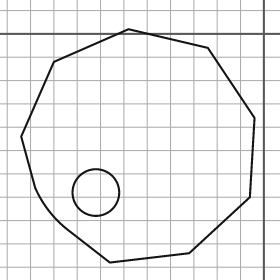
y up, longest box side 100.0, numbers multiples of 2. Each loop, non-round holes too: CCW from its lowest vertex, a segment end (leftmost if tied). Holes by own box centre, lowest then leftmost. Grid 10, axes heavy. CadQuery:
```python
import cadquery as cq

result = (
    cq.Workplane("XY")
    .moveTo(-66.0, -98.0)
    .lineTo(-32.0, -94.0)
    .lineTo(-6.0, -70.0)
    .lineTo(-4.0, -36.0)
    .lineTo(-24.0, -6.0)
    .lineTo(-58.0, 2.0)
    .lineTo(-90.0, -12.0)
    .lineTo(-104.0, -44.0)
    .lineTo(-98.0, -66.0)
    .threePointArc((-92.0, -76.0), (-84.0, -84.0))
    .close()
    .moveTo(-72.0, -68.0)
    .circle(10.0)
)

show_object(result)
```